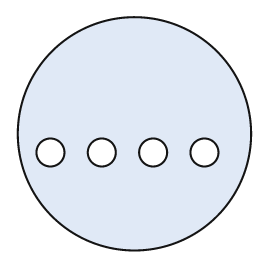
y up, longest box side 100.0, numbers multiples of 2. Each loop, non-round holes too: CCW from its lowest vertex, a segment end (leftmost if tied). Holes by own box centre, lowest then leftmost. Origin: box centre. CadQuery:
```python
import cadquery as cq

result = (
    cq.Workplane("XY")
    .moveTo(0.0, 0.0)
    .circle(50.0)
    .moveTo(-36.0, -8.0)
    .circle(6.0)
    .moveTo(-14.0, -8.0)
    .circle(6.0)
    .moveTo(8.0, -8.0)
    .circle(6.0)
    .moveTo(30.0, -8.0)
    .circle(6.0)
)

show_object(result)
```